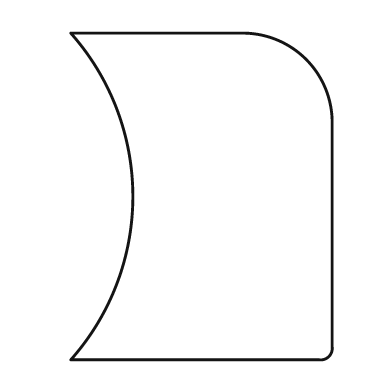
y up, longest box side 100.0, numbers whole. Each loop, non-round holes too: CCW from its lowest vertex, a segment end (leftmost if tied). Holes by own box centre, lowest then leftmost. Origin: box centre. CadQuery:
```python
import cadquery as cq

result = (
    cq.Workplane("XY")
    .moveTo(-40.0, -50.0)
    .lineTo(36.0, -50.0)
    .threePointArc((39.0, -49.0), (40.0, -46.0))
    .lineTo(40.0, 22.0)
    .threePointArc((32.0, 42.0), (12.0, 50.0))
    .lineTo(-40.0, 50.0)
    .threePointArc((-21.0, 0.0), (-40.0, -50.0))
    .close()
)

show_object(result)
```